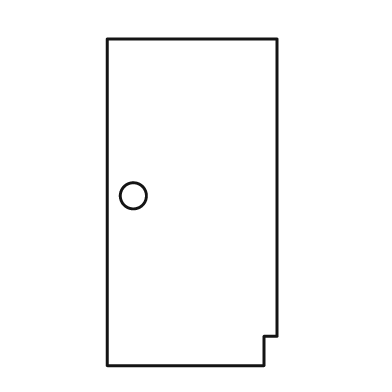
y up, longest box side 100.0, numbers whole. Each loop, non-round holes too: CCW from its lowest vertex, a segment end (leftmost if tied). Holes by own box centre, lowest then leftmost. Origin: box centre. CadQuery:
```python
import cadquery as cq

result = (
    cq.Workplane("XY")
    .moveTo(-26.0, -50.0)
    .lineTo(22.0, -50.0)
    .lineTo(22.0, -41.0)
    .lineTo(26.0, -41.0)
    .lineTo(26.0, 50.0)
    .lineTo(-26.0, 50.0)
    .close()
    .moveTo(-18.0, 2.0)
    .circle(4.0)
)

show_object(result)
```